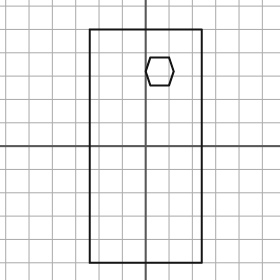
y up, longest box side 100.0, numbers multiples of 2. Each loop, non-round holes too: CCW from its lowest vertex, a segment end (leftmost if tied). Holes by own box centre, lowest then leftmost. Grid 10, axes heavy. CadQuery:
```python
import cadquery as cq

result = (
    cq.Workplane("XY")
    .moveTo(-24.0, -50.0)
    .lineTo(24.0, -50.0)
    .lineTo(24.0, 50.0)
    .lineTo(-24.0, 50.0)
    .close()
    .moveTo(2.0, 26.0)
    .lineTo(10.0, 26.0)
    .lineTo(12.0, 32.0)
    .lineTo(10.0, 38.0)
    .lineTo(2.0, 38.0)
    .lineTo(0.0, 32.0)
    .close()
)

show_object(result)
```